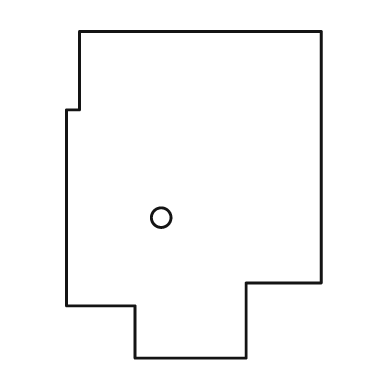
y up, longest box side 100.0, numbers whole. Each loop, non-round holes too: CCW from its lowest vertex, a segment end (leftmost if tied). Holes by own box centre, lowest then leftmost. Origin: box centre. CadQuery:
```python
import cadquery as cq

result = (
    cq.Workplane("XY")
    .moveTo(-18.0, -50.0)
    .lineTo(16.0, -50.0)
    .lineTo(16.0, -27.0)
    .lineTo(39.0, -27.0)
    .lineTo(39.0, 50.0)
    .lineTo(-35.0, 50.0)
    .lineTo(-35.0, 26.0)
    .lineTo(-39.0, 26.0)
    .lineTo(-39.0, -34.0)
    .lineTo(-18.0, -34.0)
    .close()
    .moveTo(-10.0, -7.0)
    .circle(3.0)
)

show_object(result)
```